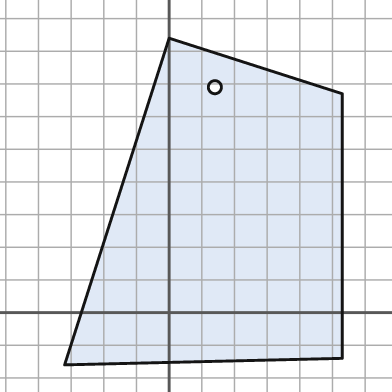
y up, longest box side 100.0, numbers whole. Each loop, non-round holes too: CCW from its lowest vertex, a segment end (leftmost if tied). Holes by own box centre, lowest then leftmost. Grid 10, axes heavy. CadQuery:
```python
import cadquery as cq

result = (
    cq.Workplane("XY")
    .moveTo(-32.0, -16.0)
    .lineTo(53.0, -14.0)
    .lineTo(53.0, 67.0)
    .lineTo(0.0, 84.0)
    .close()
    .moveTo(14.0, 69.0)
    .circle(2.0)
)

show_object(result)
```